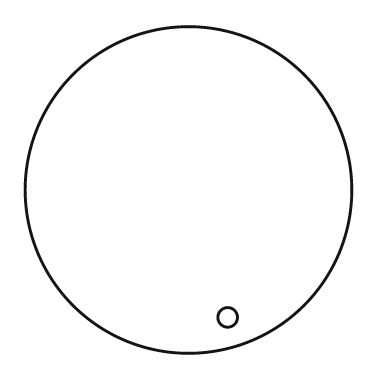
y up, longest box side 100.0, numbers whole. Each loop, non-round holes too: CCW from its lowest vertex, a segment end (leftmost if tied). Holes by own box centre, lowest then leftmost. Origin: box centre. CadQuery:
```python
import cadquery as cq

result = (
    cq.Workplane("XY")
    .moveTo(0.0, 0.0)
    .circle(50.0)
    .moveTo(12.0, -39.0)
    .circle(3.0)
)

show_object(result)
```